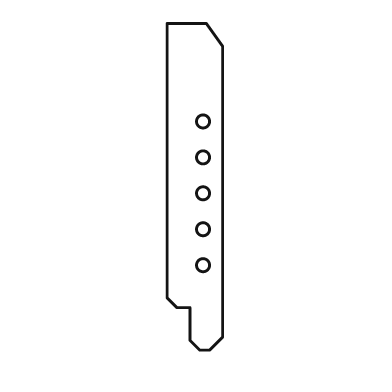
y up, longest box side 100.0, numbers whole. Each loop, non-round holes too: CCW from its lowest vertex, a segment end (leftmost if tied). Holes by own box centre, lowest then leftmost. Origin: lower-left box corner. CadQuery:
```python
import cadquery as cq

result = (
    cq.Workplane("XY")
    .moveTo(10.0, 0.0)
    .lineTo(13.0, 0.0)
    .lineTo(17.0, 4.0)
    .lineTo(17.0, 93.0)
    .lineTo(12.0, 100.0)
    .lineTo(0.0, 100.0)
    .lineTo(0.0, 16.0)
    .lineTo(3.0, 13.0)
    .lineTo(7.0, 13.0)
    .lineTo(7.0, 3.0)
    .close()
    .moveTo(11.0, 26.0)
    .circle(2.0)
    .moveTo(11.0, 37.0)
    .circle(2.0)
    .moveTo(11.0, 48.0)
    .circle(2.0)
    .moveTo(11.0, 59.0)
    .circle(2.0)
    .moveTo(11.0, 70.0)
    .circle(2.0)
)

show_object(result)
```